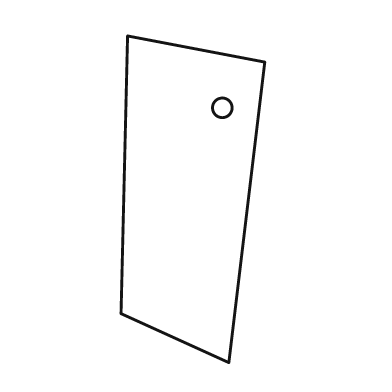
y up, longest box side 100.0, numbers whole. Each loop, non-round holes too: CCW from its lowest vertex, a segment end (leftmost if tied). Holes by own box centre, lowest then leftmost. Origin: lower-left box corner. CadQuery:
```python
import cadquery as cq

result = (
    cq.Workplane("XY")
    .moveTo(33.0, 0.0)
    .lineTo(44.0, 92.0)
    .lineTo(2.0, 100.0)
    .lineTo(0.0, 15.0)
    .close()
    .moveTo(31.0, 78.0)
    .circle(3.0)
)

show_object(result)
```